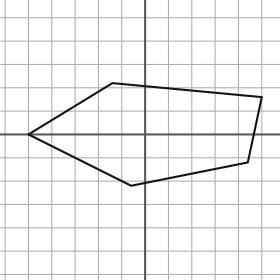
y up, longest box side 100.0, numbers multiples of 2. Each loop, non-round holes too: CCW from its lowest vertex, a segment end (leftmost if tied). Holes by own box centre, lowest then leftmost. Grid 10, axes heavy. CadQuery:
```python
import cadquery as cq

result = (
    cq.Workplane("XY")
    .moveTo(-6.0, -22.0)
    .lineTo(44.0, -12.0)
    .lineTo(50.0, 16.0)
    .lineTo(-14.0, 22.0)
    .lineTo(-50.0, 0.0)
    .close()
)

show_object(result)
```